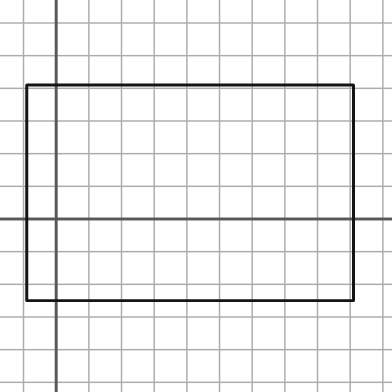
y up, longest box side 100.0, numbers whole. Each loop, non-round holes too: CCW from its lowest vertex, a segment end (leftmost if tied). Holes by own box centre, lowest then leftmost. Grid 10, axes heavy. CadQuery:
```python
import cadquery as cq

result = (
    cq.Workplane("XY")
    .moveTo(-9.0, -25.0)
    .lineTo(91.0, -25.0)
    .lineTo(91.0, 41.0)
    .lineTo(-9.0, 41.0)
    .close()
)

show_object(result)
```